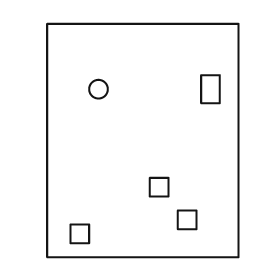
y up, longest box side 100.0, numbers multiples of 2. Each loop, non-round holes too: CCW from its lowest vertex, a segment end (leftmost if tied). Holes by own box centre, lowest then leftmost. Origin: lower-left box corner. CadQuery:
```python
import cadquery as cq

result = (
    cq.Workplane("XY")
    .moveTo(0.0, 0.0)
    .lineTo(82.0, 0.0)
    .lineTo(82.0, 100.0)
    .lineTo(0.0, 100.0)
    .close()
    .moveTo(10.0, 6.0)
    .lineTo(18.0, 6.0)
    .lineTo(18.0, 14.0)
    .lineTo(10.0, 14.0)
    .close()
    .moveTo(56.0, 12.0)
    .lineTo(64.0, 12.0)
    .lineTo(64.0, 20.0)
    .lineTo(56.0, 20.0)
    .close()
    .moveTo(44.0, 26.0)
    .lineTo(52.0, 26.0)
    .lineTo(52.0, 34.0)
    .lineTo(44.0, 34.0)
    .close()
    .moveTo(22.0, 72.0)
    .circle(4.0)
    .moveTo(66.0, 66.0)
    .lineTo(74.0, 66.0)
    .lineTo(74.0, 78.0)
    .lineTo(66.0, 78.0)
    .close()
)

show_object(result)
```